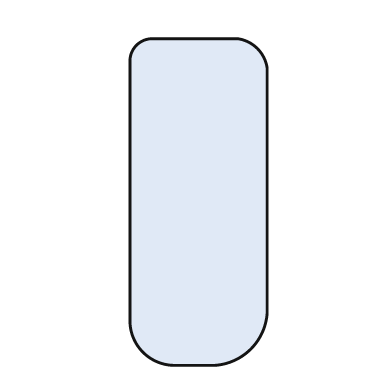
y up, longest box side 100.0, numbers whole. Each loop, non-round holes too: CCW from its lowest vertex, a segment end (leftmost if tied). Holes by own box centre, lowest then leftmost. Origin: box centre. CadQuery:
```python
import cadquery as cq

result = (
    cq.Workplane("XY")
    .moveTo(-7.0, -50.0)
    .lineTo(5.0, -50.0)
    .threePointArc((16.0, -45.0), (21.0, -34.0))
    .lineTo(21.0, 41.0)
    .threePointArc((18.0, 47.0), (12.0, 50.0))
    .lineTo(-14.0, 50.0)
    .threePointArc((-19.0, 48.0), (-21.0, 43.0))
    .lineTo(-21.0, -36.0)
    .threePointArc((-17.0, -46.0), (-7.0, -50.0))
    .close()
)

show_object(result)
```